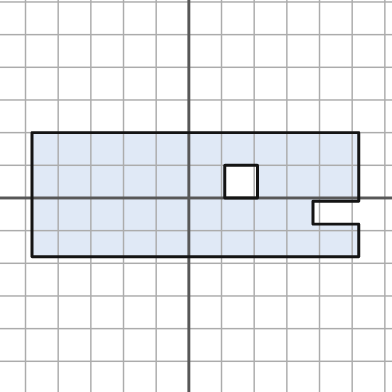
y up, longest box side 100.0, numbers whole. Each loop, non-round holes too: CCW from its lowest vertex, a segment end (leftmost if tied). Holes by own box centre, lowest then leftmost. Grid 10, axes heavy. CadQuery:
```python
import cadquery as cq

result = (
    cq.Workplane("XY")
    .moveTo(-48.0, -18.0)
    .lineTo(52.0, -18.0)
    .lineTo(52.0, -8.0)
    .lineTo(38.0, -8.0)
    .lineTo(38.0, -1.0)
    .lineTo(52.0, -1.0)
    .lineTo(52.0, 20.0)
    .lineTo(-48.0, 20.0)
    .close()
    .moveTo(11.0, 0.0)
    .lineTo(21.0, 0.0)
    .lineTo(21.0, 10.0)
    .lineTo(11.0, 10.0)
    .close()
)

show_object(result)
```